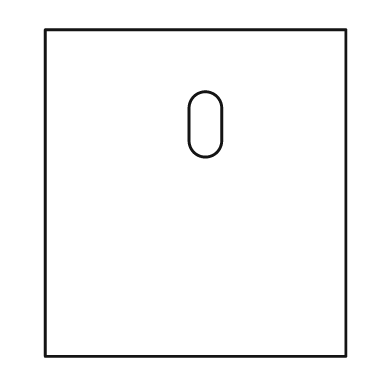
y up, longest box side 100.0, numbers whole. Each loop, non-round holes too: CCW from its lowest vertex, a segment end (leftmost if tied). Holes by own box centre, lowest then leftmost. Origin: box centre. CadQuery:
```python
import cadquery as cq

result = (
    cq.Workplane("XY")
    .moveTo(-46.0, -50.0)
    .lineTo(46.0, -50.0)
    .lineTo(46.0, 50.0)
    .lineTo(-46.0, 50.0)
    .close()
    .moveTo(-2.0, 16.0)
    .threePointArc((3.0, 11.0), (8.0, 16.0))
    .lineTo(8.0, 26.0)
    .threePointArc((3.0, 31.0), (-2.0, 26.0))
    .close()
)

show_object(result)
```